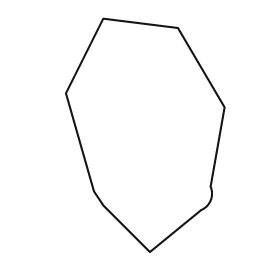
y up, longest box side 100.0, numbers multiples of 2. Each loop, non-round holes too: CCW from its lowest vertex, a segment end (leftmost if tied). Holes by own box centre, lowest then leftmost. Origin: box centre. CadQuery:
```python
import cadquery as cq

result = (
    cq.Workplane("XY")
    .moveTo(2.0, -50.0)
    .lineTo(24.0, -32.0)
    .threePointArc((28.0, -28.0), (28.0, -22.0))
    .lineTo(34.0, 12.0)
    .lineTo(14.0, 46.0)
    .lineTo(-18.0, 50.0)
    .lineTo(-34.0, 18.0)
    .lineTo(-22.0, -24.0)
    .lineTo(-18.0, -30.0)
    .close()
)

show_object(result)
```